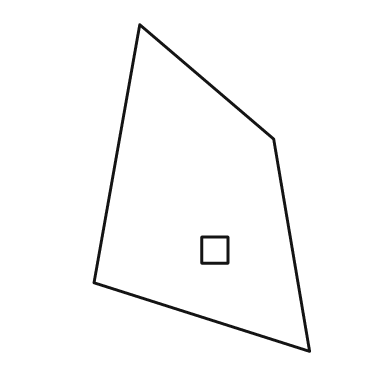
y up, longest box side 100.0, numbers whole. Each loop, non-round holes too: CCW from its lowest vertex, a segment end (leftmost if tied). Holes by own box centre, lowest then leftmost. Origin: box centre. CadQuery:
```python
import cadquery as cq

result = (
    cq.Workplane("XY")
    .moveTo(33.0, -50.0)
    .lineTo(22.0, 15.0)
    .lineTo(-19.0, 50.0)
    .lineTo(-33.0, -29.0)
    .close()
    .moveTo(0.0, -23.0)
    .lineTo(8.0, -23.0)
    .lineTo(8.0, -15.0)
    .lineTo(0.0, -15.0)
    .close()
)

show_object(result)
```